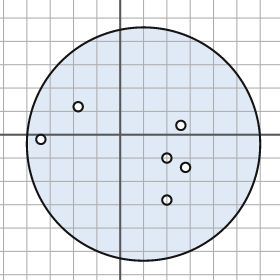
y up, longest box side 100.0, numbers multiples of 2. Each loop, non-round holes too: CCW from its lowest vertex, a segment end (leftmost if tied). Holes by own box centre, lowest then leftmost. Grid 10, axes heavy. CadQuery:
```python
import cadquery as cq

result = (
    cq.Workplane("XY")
    .moveTo(10.0, -4.0)
    .circle(50.0)
    .moveTo(20.0, -28.0)
    .circle(2.0)
    .moveTo(28.0, -14.0)
    .circle(2.0)
    .moveTo(20.0, -10.0)
    .circle(2.0)
    .moveTo(-34.0, -2.0)
    .circle(2.0)
    .moveTo(26.0, 4.0)
    .circle(2.0)
    .moveTo(-18.0, 12.0)
    .circle(2.0)
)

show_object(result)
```